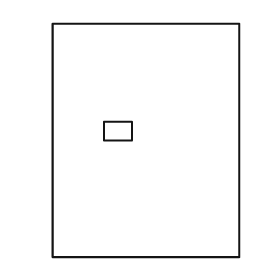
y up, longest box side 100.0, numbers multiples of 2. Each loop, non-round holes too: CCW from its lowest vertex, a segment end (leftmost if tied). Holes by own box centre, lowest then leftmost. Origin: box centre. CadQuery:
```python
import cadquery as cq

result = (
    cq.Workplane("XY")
    .moveTo(-40.0, -50.0)
    .lineTo(40.0, -50.0)
    .lineTo(40.0, 50.0)
    .lineTo(-40.0, 50.0)
    .close()
    .moveTo(-18.0, 0.0)
    .lineTo(-6.0, 0.0)
    .lineTo(-6.0, 8.0)
    .lineTo(-18.0, 8.0)
    .close()
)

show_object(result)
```